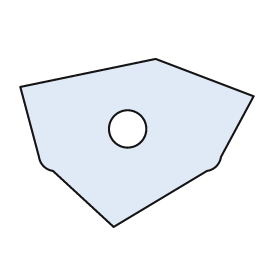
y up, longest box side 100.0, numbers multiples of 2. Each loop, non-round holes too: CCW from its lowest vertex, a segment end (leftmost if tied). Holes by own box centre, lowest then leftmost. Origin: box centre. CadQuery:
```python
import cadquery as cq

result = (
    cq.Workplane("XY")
    .moveTo(-10.0, -36.0)
    .lineTo(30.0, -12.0)
    .threePointArc((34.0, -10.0), (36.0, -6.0))
    .lineTo(50.0, 20.0)
    .lineTo(8.0, 36.0)
    .lineTo(-50.0, 24.0)
    .lineTo(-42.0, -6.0)
    .threePointArc((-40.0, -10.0), (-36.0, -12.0))
    .close()
    .moveTo(-4.0, 6.0)
    .circle(8.0)
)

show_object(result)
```